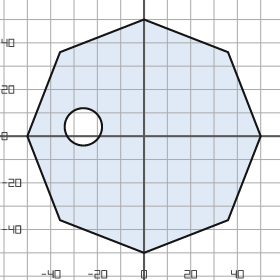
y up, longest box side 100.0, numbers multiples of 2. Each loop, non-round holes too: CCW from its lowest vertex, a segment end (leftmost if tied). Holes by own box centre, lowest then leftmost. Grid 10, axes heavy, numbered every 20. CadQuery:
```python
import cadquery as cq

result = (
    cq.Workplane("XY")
    .moveTo(0.0, -50.0)
    .lineTo(36.0, -36.0)
    .lineTo(50.0, 0.0)
    .lineTo(36.0, 36.0)
    .lineTo(0.0, 50.0)
    .lineTo(-36.0, 36.0)
    .lineTo(-50.0, 0.0)
    .lineTo(-36.0, -36.0)
    .close()
    .moveTo(-26.0, 4.0)
    .circle(8.0)
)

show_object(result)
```